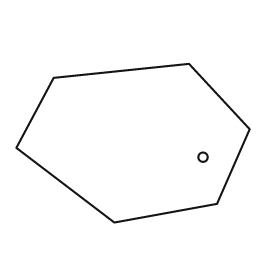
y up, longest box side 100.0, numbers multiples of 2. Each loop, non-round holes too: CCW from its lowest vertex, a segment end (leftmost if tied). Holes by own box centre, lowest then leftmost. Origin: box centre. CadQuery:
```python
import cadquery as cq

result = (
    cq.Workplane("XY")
    .moveTo(-8.0, -34.0)
    .lineTo(36.0, -26.0)
    .lineTo(50.0, 6.0)
    .lineTo(24.0, 34.0)
    .lineTo(-34.0, 28.0)
    .lineTo(-50.0, -2.0)
    .close()
    .moveTo(30.0, -6.0)
    .circle(2.0)
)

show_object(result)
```